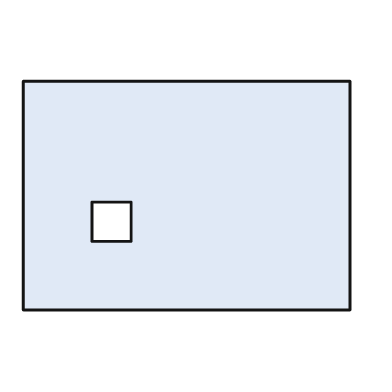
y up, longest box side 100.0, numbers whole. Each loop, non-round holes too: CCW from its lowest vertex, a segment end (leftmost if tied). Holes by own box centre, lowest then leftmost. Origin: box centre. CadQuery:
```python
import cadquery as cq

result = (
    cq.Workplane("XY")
    .moveTo(-50.0, -35.0)
    .lineTo(50.0, -35.0)
    .lineTo(50.0, 35.0)
    .lineTo(-50.0, 35.0)
    .close()
    .moveTo(-29.0, -14.0)
    .lineTo(-17.0, -14.0)
    .lineTo(-17.0, -2.0)
    .lineTo(-29.0, -2.0)
    .close()
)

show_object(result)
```